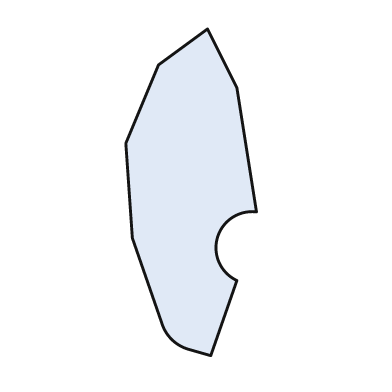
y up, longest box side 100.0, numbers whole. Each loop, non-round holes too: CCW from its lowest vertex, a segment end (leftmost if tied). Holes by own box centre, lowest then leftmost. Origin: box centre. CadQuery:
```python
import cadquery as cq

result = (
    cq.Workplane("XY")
    .moveTo(6.0, -50.0)
    .lineTo(14.0, -27.0)
    .threePointArc((8.0, -14.0), (20.0, -6.0))
    .lineTo(14.0, 32.0)
    .lineTo(5.0, 50.0)
    .lineTo(-10.0, 39.0)
    .lineTo(-20.0, 15.0)
    .lineTo(-18.0, -14.0)
    .lineTo(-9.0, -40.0)
    .threePointArc((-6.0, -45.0), (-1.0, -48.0))
    .close()
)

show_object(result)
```